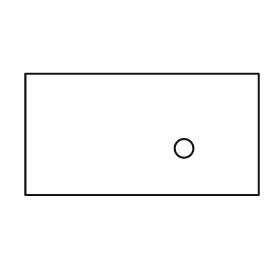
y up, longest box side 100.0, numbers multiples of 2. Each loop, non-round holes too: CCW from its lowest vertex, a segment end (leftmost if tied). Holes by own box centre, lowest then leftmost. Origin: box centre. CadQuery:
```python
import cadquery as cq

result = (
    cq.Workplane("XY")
    .moveTo(-50.0, -26.0)
    .lineTo(50.0, -26.0)
    .lineTo(50.0, 26.0)
    .lineTo(-50.0, 26.0)
    .close()
    .moveTo(18.0, -6.0)
    .circle(4.0)
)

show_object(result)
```